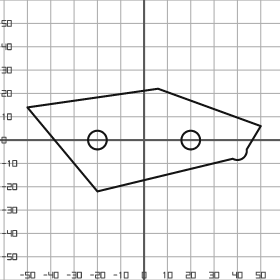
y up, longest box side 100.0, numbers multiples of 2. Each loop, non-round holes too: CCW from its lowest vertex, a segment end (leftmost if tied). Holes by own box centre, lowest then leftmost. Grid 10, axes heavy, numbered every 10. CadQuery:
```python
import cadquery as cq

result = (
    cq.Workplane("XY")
    .moveTo(-20.0, -22.0)
    .lineTo(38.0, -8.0)
    .threePointArc((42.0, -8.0), (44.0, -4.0))
    .lineTo(50.0, 6.0)
    .lineTo(6.0, 22.0)
    .lineTo(-50.0, 14.0)
    .close()
    .moveTo(-20.0, 0.0)
    .circle(4.0)
    .moveTo(20.0, 0.0)
    .circle(4.0)
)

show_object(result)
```